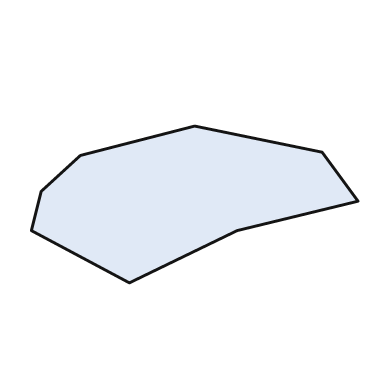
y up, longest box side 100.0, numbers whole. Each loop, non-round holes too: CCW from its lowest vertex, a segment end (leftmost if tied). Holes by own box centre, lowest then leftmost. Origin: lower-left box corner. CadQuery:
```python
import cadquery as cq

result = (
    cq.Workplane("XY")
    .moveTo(30.0, 0.0)
    .lineTo(63.0, 16.0)
    .lineTo(100.0, 25.0)
    .lineTo(89.0, 40.0)
    .lineTo(50.0, 48.0)
    .lineTo(15.0, 39.0)
    .lineTo(3.0, 28.0)
    .lineTo(0.0, 16.0)
    .close()
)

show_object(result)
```